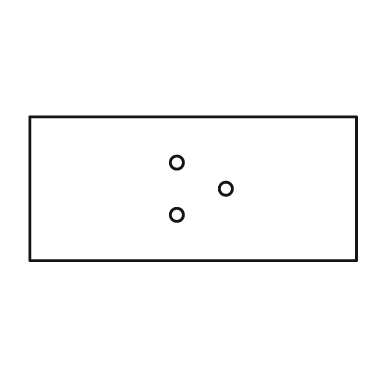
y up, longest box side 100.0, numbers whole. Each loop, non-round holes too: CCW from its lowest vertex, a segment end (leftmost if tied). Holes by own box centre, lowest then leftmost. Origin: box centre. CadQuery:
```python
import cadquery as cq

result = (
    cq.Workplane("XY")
    .moveTo(-50.0, -22.0)
    .lineTo(50.0, -22.0)
    .lineTo(50.0, 22.0)
    .lineTo(-50.0, 22.0)
    .close()
    .moveTo(-5.0, -8.0)
    .circle(2.0)
    .moveTo(10.0, 0.0)
    .circle(2.0)
    .moveTo(-5.0, 8.0)
    .circle(2.0)
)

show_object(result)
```